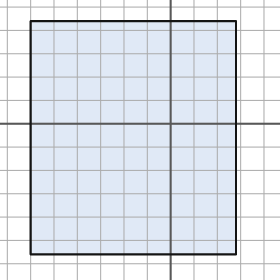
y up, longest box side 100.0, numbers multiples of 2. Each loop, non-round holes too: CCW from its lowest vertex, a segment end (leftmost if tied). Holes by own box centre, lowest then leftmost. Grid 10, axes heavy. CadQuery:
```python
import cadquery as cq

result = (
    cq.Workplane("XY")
    .moveTo(-60.0, -56.0)
    .lineTo(28.0, -56.0)
    .lineTo(28.0, 44.0)
    .lineTo(-60.0, 44.0)
    .close()
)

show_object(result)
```